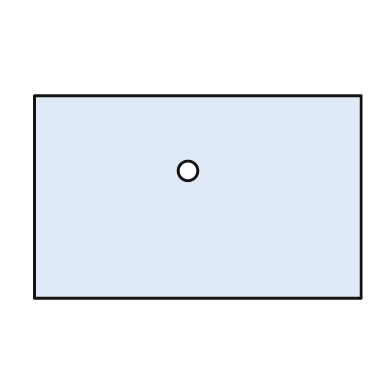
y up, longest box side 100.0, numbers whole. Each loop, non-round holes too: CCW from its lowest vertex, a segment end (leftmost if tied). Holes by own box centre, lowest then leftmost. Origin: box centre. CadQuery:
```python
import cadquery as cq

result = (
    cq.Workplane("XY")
    .moveTo(-50.0, -31.0)
    .lineTo(50.0, -31.0)
    .lineTo(50.0, 31.0)
    .lineTo(-50.0, 31.0)
    .close()
    .moveTo(-3.0, 8.0)
    .circle(3.0)
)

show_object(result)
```